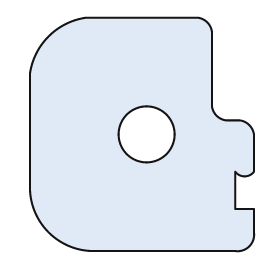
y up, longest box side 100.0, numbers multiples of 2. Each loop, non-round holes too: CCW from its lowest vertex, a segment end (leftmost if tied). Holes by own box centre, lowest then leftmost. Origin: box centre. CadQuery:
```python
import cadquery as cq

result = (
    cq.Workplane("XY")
    .moveTo(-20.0, -50.0)
    .lineTo(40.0, -50.0)
    .threePointArc((46.0, -48.0), (48.0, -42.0))
    .lineTo(48.0, -32.0)
    .lineTo(40.0, -32.0)
    .lineTo(40.0, -16.0)
    .threePointArc((44.0, -18.0), (48.0, -16.0))
    .lineTo(48.0, 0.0)
    .threePointArc((46.0, 4.0), (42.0, 6.0))
    .lineTo(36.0, 6.0)
    .threePointArc((32.0, 8.0), (30.0, 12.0))
    .lineTo(30.0, 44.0)
    .threePointArc((28.0, 48.0), (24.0, 50.0))
    .lineTo(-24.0, 50.0)
    .threePointArc((-40.0, 42.0), (-48.0, 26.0))
    .lineTo(-48.0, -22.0)
    .threePointArc((-40.0, -42.0), (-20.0, -50.0))
    .close()
    .moveTo(2.0, 0.0)
    .circle(12.0)
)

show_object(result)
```